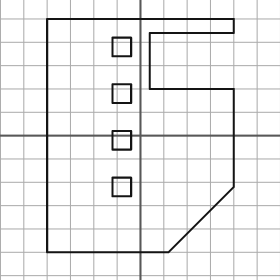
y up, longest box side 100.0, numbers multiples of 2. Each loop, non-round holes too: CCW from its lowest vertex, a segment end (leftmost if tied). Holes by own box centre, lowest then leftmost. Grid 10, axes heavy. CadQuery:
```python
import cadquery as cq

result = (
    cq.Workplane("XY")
    .moveTo(-40.0, -50.0)
    .lineTo(12.0, -50.0)
    .lineTo(40.0, -22.0)
    .lineTo(40.0, 20.0)
    .lineTo(4.0, 20.0)
    .lineTo(4.0, 44.0)
    .lineTo(40.0, 44.0)
    .lineTo(40.0, 50.0)
    .lineTo(-40.0, 50.0)
    .close()
    .moveTo(-12.0, -26.0)
    .lineTo(-4.0, -26.0)
    .lineTo(-4.0, -18.0)
    .lineTo(-12.0, -18.0)
    .close()
    .moveTo(-12.0, -6.0)
    .lineTo(-4.0, -6.0)
    .lineTo(-4.0, 2.0)
    .lineTo(-12.0, 2.0)
    .close()
    .moveTo(-12.0, 14.0)
    .lineTo(-4.0, 14.0)
    .lineTo(-4.0, 22.0)
    .lineTo(-12.0, 22.0)
    .close()
    .moveTo(-12.0, 34.0)
    .lineTo(-4.0, 34.0)
    .lineTo(-4.0, 42.0)
    .lineTo(-12.0, 42.0)
    .close()
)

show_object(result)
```